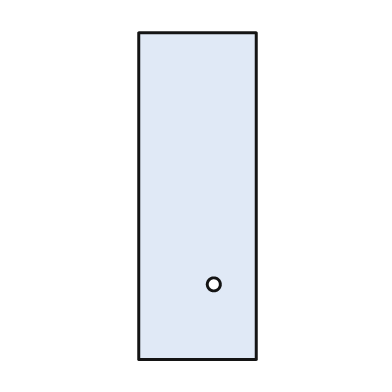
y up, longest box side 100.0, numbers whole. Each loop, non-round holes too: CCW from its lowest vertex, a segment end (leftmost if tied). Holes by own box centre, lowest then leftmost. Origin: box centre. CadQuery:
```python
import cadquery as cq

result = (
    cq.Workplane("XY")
    .moveTo(-18.0, -50.0)
    .lineTo(18.0, -50.0)
    .lineTo(18.0, 50.0)
    .lineTo(-18.0, 50.0)
    .close()
    .moveTo(5.0, -27.0)
    .circle(2.0)
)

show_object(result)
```